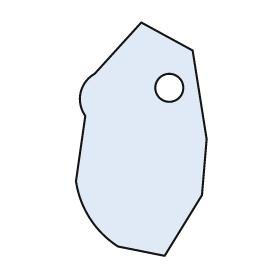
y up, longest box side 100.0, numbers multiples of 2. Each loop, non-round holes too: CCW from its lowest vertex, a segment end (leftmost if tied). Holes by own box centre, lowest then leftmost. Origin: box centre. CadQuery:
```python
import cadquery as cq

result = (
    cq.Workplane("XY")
    .moveTo(10.0, -50.0)
    .lineTo(26.0, -24.0)
    .lineTo(28.0, 0.0)
    .lineTo(22.0, 38.0)
    .lineTo(0.0, 50.0)
    .lineTo(-20.0, 28.0)
    .threePointArc((-26.0, 20.0), (-24.0, 10.0))
    .lineTo(-28.0, -18.0)
    .threePointArc((-22.0, -34.0), (-10.0, -46.0))
    .close()
    .moveTo(12.0, 22.0)
    .circle(6.0)
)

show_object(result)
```